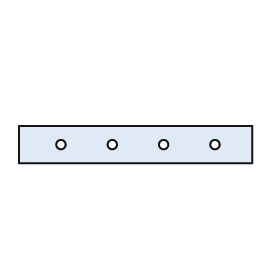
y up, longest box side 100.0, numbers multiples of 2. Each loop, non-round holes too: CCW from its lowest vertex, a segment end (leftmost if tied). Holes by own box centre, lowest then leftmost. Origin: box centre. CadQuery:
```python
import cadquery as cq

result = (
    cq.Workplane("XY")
    .moveTo(-50.0, -8.0)
    .lineTo(50.0, -8.0)
    .lineTo(50.0, 8.0)
    .lineTo(-50.0, 8.0)
    .close()
    .moveTo(-32.0, 0.0)
    .circle(2.0)
    .moveTo(-10.0, 0.0)
    .circle(2.0)
    .moveTo(12.0, 0.0)
    .circle(2.0)
    .moveTo(34.0, 0.0)
    .circle(2.0)
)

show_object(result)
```